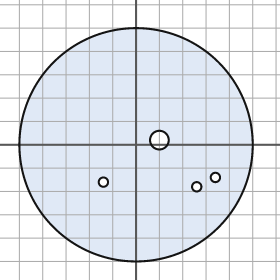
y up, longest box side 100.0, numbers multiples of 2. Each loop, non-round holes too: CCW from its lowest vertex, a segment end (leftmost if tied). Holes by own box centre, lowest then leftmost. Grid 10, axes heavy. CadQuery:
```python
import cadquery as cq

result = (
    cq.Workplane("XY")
    .moveTo(0.0, 0.0)
    .circle(50.0)
    .moveTo(26.0, -18.0)
    .circle(2.0)
    .moveTo(-14.0, -16.0)
    .circle(2.0)
    .moveTo(34.0, -14.0)
    .circle(2.0)
    .moveTo(10.0, 2.0)
    .circle(4.0)
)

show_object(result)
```